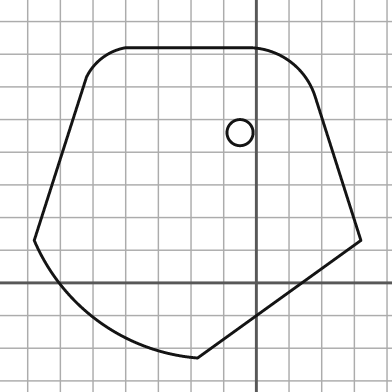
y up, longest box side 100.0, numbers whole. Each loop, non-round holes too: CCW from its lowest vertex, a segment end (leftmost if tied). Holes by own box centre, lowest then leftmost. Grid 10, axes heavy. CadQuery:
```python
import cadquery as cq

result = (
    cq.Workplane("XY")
    .moveTo(-18.0, -23.0)
    .lineTo(32.0, 13.0)
    .lineTo(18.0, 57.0)
    .threePointArc((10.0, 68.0), (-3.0, 72.0))
    .lineTo(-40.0, 72.0)
    .threePointArc((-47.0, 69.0), (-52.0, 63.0))
    .lineTo(-68.0, 13.0)
    .threePointArc((-48.0, -12.0), (-18.0, -23.0))
    .close()
    .moveTo(-5.0, 46.0)
    .circle(4.0)
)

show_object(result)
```